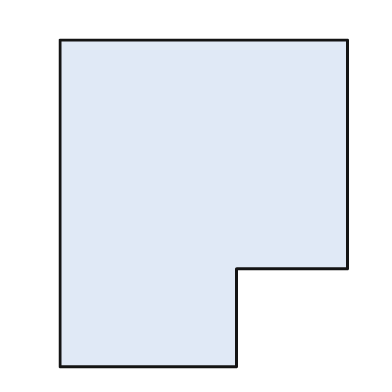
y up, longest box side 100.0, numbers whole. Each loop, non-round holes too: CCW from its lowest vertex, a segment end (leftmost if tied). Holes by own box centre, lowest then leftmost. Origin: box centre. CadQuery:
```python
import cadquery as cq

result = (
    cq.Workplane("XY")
    .moveTo(-44.0, -50.0)
    .lineTo(10.0, -50.0)
    .lineTo(10.0, -20.0)
    .lineTo(44.0, -20.0)
    .lineTo(44.0, 50.0)
    .lineTo(-44.0, 50.0)
    .close()
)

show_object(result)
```